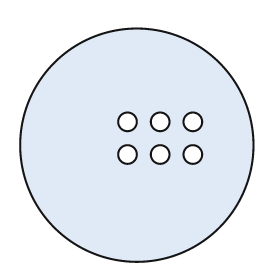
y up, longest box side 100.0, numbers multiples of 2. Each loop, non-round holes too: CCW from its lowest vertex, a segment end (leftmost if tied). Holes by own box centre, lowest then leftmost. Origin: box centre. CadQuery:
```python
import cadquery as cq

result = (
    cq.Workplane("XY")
    .moveTo(0.0, 0.0)
    .circle(50.0)
    .moveTo(-4.0, -4.0)
    .circle(4.0)
    .moveTo(10.0, -4.0)
    .circle(4.0)
    .moveTo(24.0, -4.0)
    .circle(4.0)
    .moveTo(-4.0, 10.0)
    .circle(4.0)
    .moveTo(10.0, 10.0)
    .circle(4.0)
    .moveTo(24.0, 10.0)
    .circle(4.0)
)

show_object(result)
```